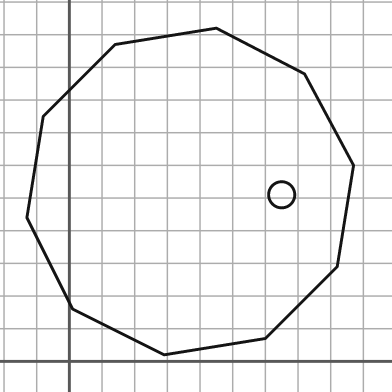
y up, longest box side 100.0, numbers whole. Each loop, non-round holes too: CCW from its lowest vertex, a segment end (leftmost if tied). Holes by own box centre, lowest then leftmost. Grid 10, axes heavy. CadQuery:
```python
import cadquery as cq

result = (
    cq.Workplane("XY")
    .moveTo(29.0, 2.0)
    .lineTo(60.0, 7.0)
    .lineTo(82.0, 29.0)
    .lineTo(87.0, 60.0)
    .lineTo(72.0, 88.0)
    .lineTo(45.0, 102.0)
    .lineTo(14.0, 97.0)
    .lineTo(-8.0, 75.0)
    .lineTo(-13.0, 44.0)
    .lineTo(1.0, 16.0)
    .close()
    .moveTo(65.0, 51.0)
    .circle(4.0)
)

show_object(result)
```